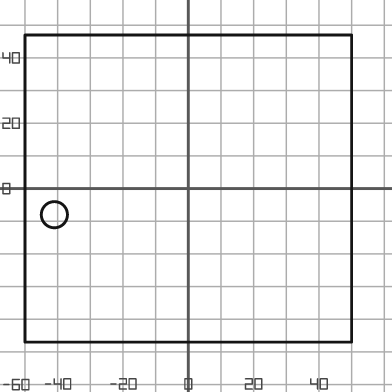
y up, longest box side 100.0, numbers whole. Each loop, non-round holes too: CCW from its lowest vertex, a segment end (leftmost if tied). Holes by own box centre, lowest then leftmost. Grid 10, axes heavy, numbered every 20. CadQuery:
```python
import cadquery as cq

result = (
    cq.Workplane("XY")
    .moveTo(-50.0, -47.0)
    .lineTo(50.0, -47.0)
    .lineTo(50.0, 47.0)
    .lineTo(-50.0, 47.0)
    .close()
    .moveTo(-41.0, -8.0)
    .circle(4.0)
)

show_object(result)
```